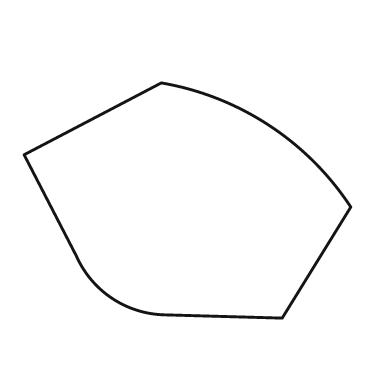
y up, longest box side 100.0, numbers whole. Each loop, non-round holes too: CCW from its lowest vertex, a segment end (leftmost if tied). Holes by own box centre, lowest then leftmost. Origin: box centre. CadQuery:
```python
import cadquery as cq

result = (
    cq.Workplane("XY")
    .moveTo(29.0, -36.0)
    .lineTo(50.0, -2.0)
    .threePointArc((25.0, 23.0), (-8.0, 36.0))
    .lineTo(-50.0, 14.0)
    .lineTo(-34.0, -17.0)
    .threePointArc((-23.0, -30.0), (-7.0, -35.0))
    .close()
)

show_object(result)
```